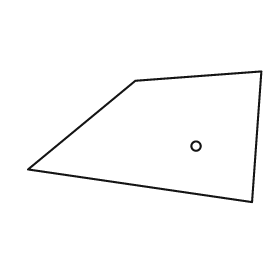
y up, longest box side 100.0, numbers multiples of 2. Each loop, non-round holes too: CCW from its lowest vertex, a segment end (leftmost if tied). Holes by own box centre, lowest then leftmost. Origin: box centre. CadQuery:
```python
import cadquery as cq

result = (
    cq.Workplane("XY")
    .moveTo(46.0, -28.0)
    .lineTo(50.0, 28.0)
    .lineTo(-4.0, 24.0)
    .lineTo(-50.0, -14.0)
    .close()
    .moveTo(22.0, -4.0)
    .circle(2.0)
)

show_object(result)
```